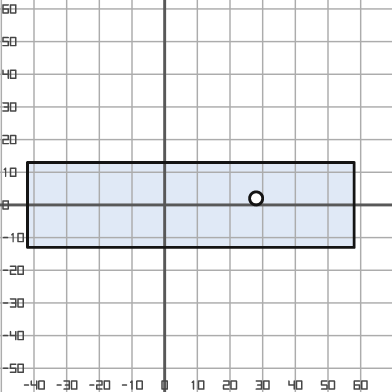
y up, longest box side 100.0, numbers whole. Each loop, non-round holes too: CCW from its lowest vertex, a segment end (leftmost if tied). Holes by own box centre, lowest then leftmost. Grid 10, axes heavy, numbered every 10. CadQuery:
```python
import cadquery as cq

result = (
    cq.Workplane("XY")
    .moveTo(-42.0, -13.0)
    .lineTo(58.0, -13.0)
    .lineTo(58.0, 13.0)
    .lineTo(-42.0, 13.0)
    .close()
    .moveTo(28.0, 2.0)
    .circle(2.0)
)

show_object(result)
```